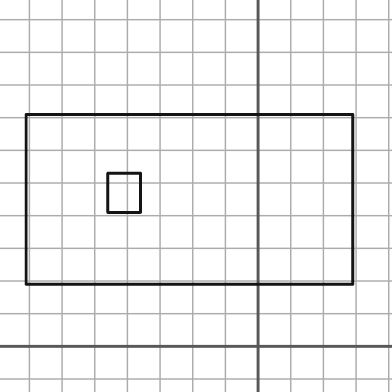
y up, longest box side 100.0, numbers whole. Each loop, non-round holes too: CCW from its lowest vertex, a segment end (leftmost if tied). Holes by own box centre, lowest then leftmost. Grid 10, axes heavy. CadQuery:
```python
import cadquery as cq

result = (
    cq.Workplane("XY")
    .moveTo(-71.0, 19.0)
    .lineTo(29.0, 19.0)
    .lineTo(29.0, 71.0)
    .lineTo(-71.0, 71.0)
    .close()
    .moveTo(-46.0, 41.0)
    .lineTo(-36.0, 41.0)
    .lineTo(-36.0, 53.0)
    .lineTo(-46.0, 53.0)
    .close()
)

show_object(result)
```